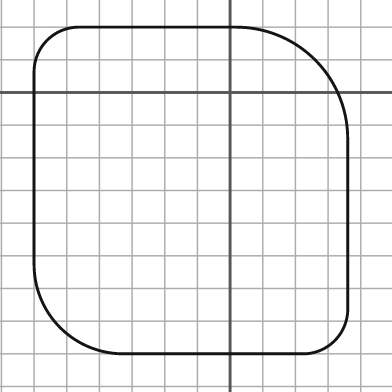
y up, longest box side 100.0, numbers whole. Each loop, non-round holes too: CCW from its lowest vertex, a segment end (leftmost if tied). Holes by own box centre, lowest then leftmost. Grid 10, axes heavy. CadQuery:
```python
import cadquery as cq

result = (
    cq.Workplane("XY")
    .moveTo(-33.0, -80.0)
    .lineTo(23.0, -80.0)
    .threePointArc((32.0, -76.0), (36.0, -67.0))
    .lineTo(36.0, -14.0)
    .threePointArc((26.0, 10.0), (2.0, 20.0))
    .lineTo(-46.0, 20.0)
    .threePointArc((-56.0, 16.0), (-60.0, 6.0))
    .lineTo(-60.0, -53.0)
    .threePointArc((-52.0, -72.0), (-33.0, -80.0))
    .close()
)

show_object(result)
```